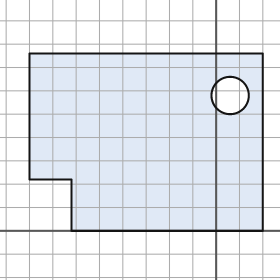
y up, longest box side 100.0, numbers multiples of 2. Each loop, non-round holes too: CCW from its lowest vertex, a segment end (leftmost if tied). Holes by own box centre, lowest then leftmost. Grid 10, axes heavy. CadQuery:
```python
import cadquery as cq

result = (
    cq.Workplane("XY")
    .moveTo(-62.0, 0.0)
    .lineTo(20.0, 0.0)
    .lineTo(20.0, 76.0)
    .lineTo(-80.0, 76.0)
    .lineTo(-80.0, 22.0)
    .lineTo(-62.0, 22.0)
    .close()
    .moveTo(6.0, 58.0)
    .circle(8.0)
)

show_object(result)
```